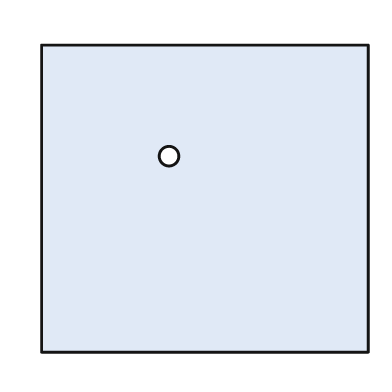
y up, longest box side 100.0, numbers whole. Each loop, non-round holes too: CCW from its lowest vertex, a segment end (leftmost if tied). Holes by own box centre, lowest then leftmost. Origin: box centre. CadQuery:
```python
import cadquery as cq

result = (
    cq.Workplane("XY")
    .moveTo(-50.0, -47.0)
    .lineTo(50.0, -47.0)
    .lineTo(50.0, 47.0)
    .lineTo(-50.0, 47.0)
    .close()
    .moveTo(-11.0, 13.0)
    .circle(3.0)
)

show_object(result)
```